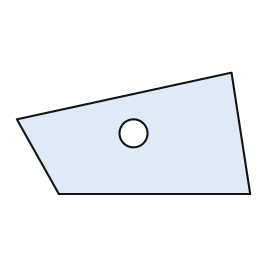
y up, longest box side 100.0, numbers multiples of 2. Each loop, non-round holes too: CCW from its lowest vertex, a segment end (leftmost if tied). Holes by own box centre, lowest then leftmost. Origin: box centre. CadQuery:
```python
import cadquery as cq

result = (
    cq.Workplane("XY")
    .moveTo(-32.0, -26.0)
    .lineTo(50.0, -26.0)
    .lineTo(42.0, 26.0)
    .lineTo(-50.0, 6.0)
    .close()
    .moveTo(0.0, 0.0)
    .circle(6.0)
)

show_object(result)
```